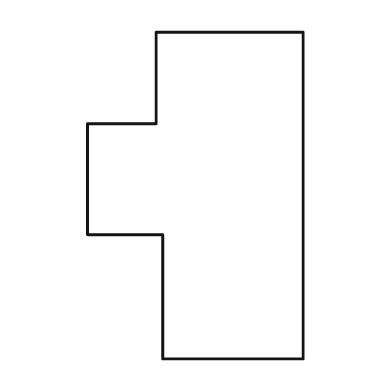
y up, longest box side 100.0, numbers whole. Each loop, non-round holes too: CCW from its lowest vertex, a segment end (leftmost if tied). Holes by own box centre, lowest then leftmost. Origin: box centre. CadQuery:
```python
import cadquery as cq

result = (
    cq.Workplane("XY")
    .moveTo(-10.0, -50.0)
    .lineTo(33.0, -50.0)
    .lineTo(33.0, 50.0)
    .lineTo(-12.0, 50.0)
    .lineTo(-12.0, 22.0)
    .lineTo(-33.0, 22.0)
    .lineTo(-33.0, -12.0)
    .lineTo(-10.0, -12.0)
    .close()
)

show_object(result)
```